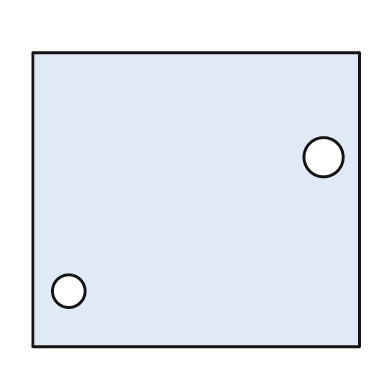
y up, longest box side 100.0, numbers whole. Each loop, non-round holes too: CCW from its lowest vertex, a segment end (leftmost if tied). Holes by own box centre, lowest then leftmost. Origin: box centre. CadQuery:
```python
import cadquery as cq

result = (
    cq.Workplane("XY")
    .moveTo(-50.0, -45.0)
    .lineTo(50.0, -45.0)
    .lineTo(50.0, 45.0)
    .lineTo(-50.0, 45.0)
    .close()
    .moveTo(-39.0, -28.0)
    .circle(5.0)
    .moveTo(39.0, 13.0)
    .circle(6.0)
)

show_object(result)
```